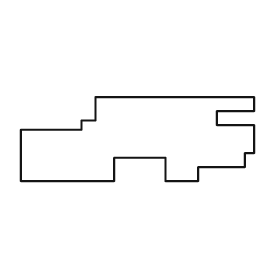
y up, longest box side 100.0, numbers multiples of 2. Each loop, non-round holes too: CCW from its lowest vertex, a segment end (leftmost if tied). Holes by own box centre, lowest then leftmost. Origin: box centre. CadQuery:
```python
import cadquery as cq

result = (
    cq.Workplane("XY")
    .moveTo(-50.0, -18.0)
    .lineTo(-10.0, -18.0)
    .lineTo(-10.0, -8.0)
    .lineTo(12.0, -8.0)
    .lineTo(12.0, -18.0)
    .lineTo(26.0, -18.0)
    .lineTo(26.0, -12.0)
    .lineTo(46.0, -12.0)
    .lineTo(46.0, -6.0)
    .lineTo(50.0, -6.0)
    .lineTo(50.0, 6.0)
    .lineTo(34.0, 6.0)
    .lineTo(34.0, 12.0)
    .lineTo(50.0, 12.0)
    .lineTo(50.0, 18.0)
    .lineTo(-18.0, 18.0)
    .lineTo(-18.0, 8.0)
    .lineTo(-24.0, 8.0)
    .lineTo(-24.0, 4.0)
    .lineTo(-50.0, 4.0)
    .close()
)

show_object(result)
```